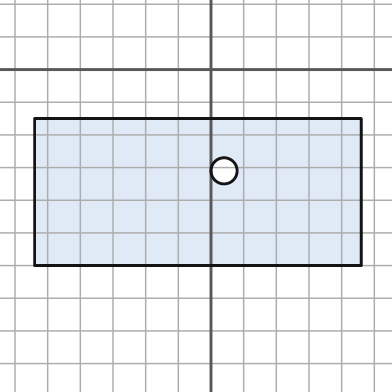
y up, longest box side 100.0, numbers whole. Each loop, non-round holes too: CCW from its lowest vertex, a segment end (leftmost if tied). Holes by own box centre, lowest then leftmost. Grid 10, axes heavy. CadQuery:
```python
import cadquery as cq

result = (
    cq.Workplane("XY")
    .moveTo(-54.0, -60.0)
    .lineTo(46.0, -60.0)
    .lineTo(46.0, -15.0)
    .lineTo(-54.0, -15.0)
    .close()
    .moveTo(4.0, -31.0)
    .circle(4.0)
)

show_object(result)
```